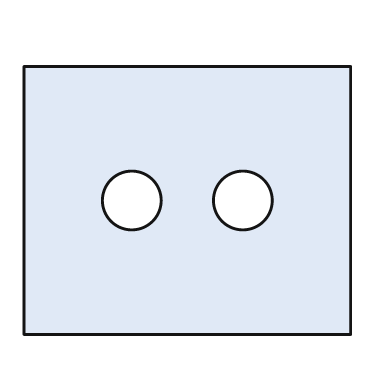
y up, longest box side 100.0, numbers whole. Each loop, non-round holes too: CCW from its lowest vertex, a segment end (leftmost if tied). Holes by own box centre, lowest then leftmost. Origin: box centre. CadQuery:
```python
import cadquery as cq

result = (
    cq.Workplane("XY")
    .moveTo(-50.0, -41.0)
    .lineTo(50.0, -41.0)
    .lineTo(50.0, 41.0)
    .lineTo(-50.0, 41.0)
    .close()
    .moveTo(-17.0, 0.0)
    .circle(9.0)
    .moveTo(17.0, 0.0)
    .circle(9.0)
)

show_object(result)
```